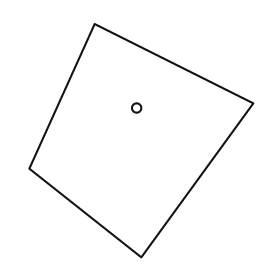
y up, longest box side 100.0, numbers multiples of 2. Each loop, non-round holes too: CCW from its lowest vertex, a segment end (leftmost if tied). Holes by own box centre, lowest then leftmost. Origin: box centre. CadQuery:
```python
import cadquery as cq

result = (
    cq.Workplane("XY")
    .moveTo(0.0, -50.0)
    .lineTo(48.0, 16.0)
    .lineTo(-20.0, 50.0)
    .lineTo(-48.0, -12.0)
    .close()
    .moveTo(-2.0, 14.0)
    .circle(2.0)
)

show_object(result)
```